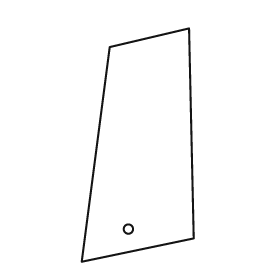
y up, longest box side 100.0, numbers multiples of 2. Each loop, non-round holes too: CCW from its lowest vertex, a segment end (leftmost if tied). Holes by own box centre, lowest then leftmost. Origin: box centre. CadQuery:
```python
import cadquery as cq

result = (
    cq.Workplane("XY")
    .moveTo(-24.0, -50.0)
    .lineTo(24.0, -40.0)
    .lineTo(22.0, 50.0)
    .lineTo(-12.0, 42.0)
    .close()
    .moveTo(-4.0, -36.0)
    .circle(2.0)
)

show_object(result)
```